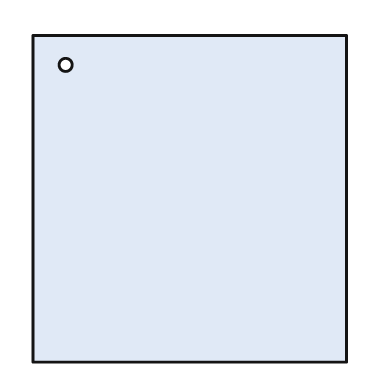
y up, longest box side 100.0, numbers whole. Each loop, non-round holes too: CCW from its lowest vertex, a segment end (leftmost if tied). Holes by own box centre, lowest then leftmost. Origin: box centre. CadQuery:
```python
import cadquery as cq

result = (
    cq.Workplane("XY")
    .moveTo(-48.0, -50.0)
    .lineTo(48.0, -50.0)
    .lineTo(48.0, 50.0)
    .lineTo(-48.0, 50.0)
    .close()
    .moveTo(-38.0, 41.0)
    .circle(2.0)
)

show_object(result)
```